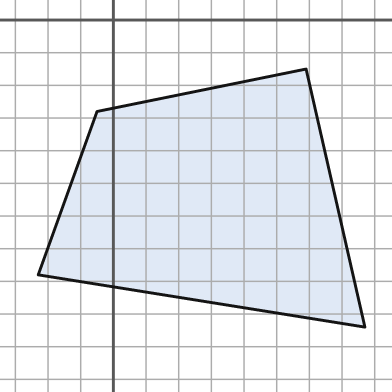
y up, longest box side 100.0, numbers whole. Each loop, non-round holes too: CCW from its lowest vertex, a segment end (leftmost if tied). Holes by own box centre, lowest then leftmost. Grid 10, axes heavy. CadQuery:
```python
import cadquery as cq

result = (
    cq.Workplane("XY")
    .moveTo(77.0, -94.0)
    .lineTo(59.0, -15.0)
    .lineTo(-5.0, -28.0)
    .lineTo(-23.0, -78.0)
    .close()
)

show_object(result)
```